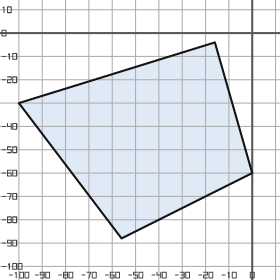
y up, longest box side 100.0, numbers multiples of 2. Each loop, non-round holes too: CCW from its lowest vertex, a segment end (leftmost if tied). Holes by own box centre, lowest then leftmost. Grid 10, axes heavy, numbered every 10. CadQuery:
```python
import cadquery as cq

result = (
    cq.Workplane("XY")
    .moveTo(-56.0, -88.0)
    .lineTo(0.0, -60.0)
    .lineTo(-16.0, -4.0)
    .lineTo(-100.0, -30.0)
    .close()
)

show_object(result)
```